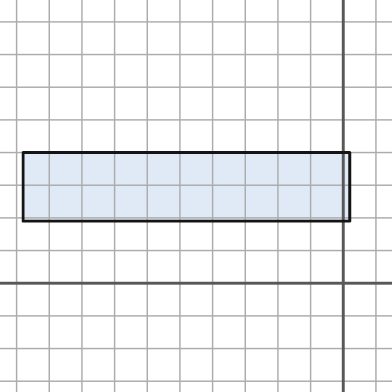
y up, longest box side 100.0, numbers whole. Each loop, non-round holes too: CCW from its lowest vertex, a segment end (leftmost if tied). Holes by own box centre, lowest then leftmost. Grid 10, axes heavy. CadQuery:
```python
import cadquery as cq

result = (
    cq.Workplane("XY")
    .moveTo(-98.0, 19.0)
    .lineTo(2.0, 19.0)
    .lineTo(2.0, 40.0)
    .lineTo(-98.0, 40.0)
    .close()
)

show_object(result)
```